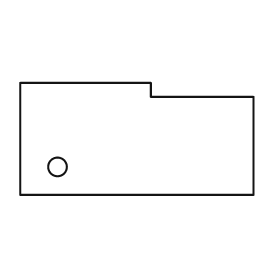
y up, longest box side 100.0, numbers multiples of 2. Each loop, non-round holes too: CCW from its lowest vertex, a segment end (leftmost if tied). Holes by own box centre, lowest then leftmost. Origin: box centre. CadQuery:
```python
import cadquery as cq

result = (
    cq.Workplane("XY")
    .moveTo(-50.0, -24.0)
    .lineTo(50.0, -24.0)
    .lineTo(50.0, 18.0)
    .lineTo(6.0, 18.0)
    .lineTo(6.0, 24.0)
    .lineTo(-50.0, 24.0)
    .close()
    .moveTo(-34.0, -12.0)
    .circle(4.0)
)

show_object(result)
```